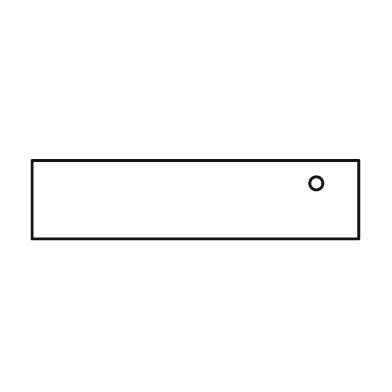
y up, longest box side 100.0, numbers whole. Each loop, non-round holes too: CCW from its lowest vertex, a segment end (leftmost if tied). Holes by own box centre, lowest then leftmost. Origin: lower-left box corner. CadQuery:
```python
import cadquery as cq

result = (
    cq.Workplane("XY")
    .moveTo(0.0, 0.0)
    .lineTo(100.0, 0.0)
    .lineTo(100.0, 24.0)
    .lineTo(0.0, 24.0)
    .close()
    .moveTo(87.0, 17.0)
    .circle(2.0)
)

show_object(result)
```